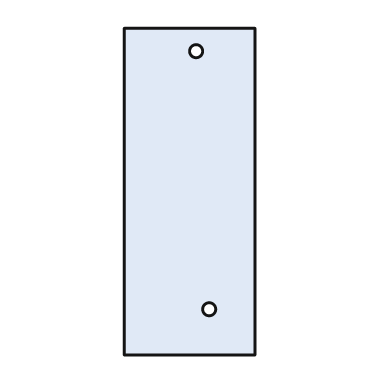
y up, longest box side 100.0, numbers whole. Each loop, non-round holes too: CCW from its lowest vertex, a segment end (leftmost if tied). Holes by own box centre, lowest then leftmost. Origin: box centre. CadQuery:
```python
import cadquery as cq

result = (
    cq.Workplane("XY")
    .moveTo(-20.0, -50.0)
    .lineTo(20.0, -50.0)
    .lineTo(20.0, 50.0)
    .lineTo(-20.0, 50.0)
    .close()
    .moveTo(6.0, -36.0)
    .circle(2.0)
    .moveTo(2.0, 43.0)
    .circle(2.0)
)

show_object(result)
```